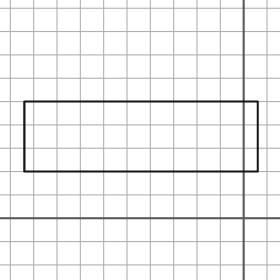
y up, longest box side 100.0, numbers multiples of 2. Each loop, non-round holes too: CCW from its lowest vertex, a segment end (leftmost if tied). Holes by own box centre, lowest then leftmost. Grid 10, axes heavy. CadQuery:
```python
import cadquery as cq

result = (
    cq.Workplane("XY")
    .moveTo(-94.0, 20.0)
    .lineTo(6.0, 20.0)
    .lineTo(6.0, 50.0)
    .lineTo(-94.0, 50.0)
    .close()
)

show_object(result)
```